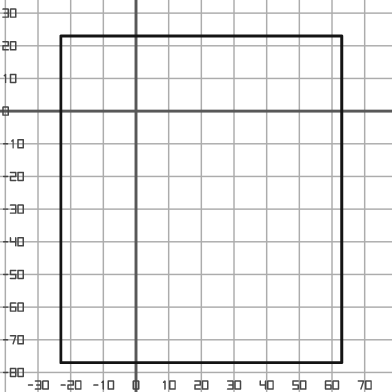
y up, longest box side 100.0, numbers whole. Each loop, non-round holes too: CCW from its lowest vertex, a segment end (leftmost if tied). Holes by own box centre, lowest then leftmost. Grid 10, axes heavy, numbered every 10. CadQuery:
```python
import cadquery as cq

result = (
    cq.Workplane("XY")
    .moveTo(-23.0, -77.0)
    .lineTo(63.0, -77.0)
    .lineTo(63.0, 23.0)
    .lineTo(-23.0, 23.0)
    .close()
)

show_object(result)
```